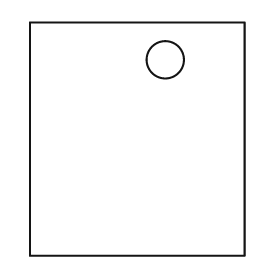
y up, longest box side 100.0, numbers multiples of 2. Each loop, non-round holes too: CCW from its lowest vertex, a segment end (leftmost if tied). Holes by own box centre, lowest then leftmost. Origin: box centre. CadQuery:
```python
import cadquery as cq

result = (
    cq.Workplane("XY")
    .moveTo(-46.0, -50.0)
    .lineTo(46.0, -50.0)
    .lineTo(46.0, 50.0)
    .lineTo(-46.0, 50.0)
    .close()
    .moveTo(12.0, 34.0)
    .circle(8.0)
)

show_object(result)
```